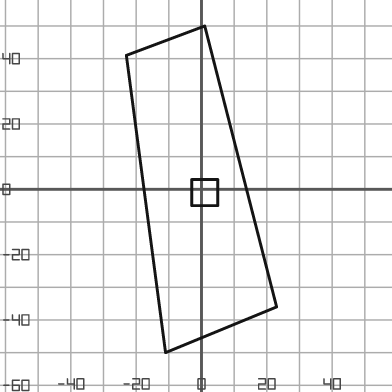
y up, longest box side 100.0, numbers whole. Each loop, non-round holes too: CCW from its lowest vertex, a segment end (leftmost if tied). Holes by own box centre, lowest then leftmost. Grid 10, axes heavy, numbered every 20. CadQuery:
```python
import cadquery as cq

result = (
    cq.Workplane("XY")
    .moveTo(-11.0, -50.0)
    .lineTo(23.0, -36.0)
    .lineTo(1.0, 50.0)
    .lineTo(-23.0, 41.0)
    .close()
    .moveTo(-3.0, -5.0)
    .lineTo(5.0, -5.0)
    .lineTo(5.0, 3.0)
    .lineTo(-3.0, 3.0)
    .close()
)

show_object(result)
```